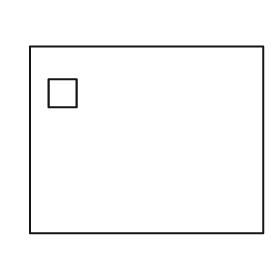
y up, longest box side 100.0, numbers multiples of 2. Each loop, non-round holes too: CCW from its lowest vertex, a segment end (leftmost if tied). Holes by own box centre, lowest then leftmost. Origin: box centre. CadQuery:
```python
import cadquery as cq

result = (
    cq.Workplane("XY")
    .moveTo(-50.0, -40.0)
    .lineTo(50.0, -40.0)
    .lineTo(50.0, 40.0)
    .lineTo(-50.0, 40.0)
    .close()
    .moveTo(-42.0, 14.0)
    .lineTo(-30.0, 14.0)
    .lineTo(-30.0, 26.0)
    .lineTo(-42.0, 26.0)
    .close()
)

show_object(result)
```